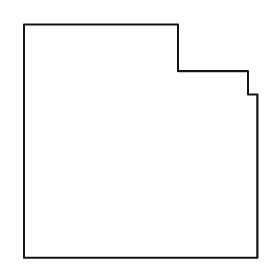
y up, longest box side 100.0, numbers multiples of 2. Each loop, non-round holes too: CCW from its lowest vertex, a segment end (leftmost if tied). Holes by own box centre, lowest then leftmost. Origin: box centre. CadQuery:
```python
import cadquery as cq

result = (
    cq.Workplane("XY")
    .moveTo(-50.0, -50.0)
    .lineTo(50.0, -50.0)
    .lineTo(50.0, 20.0)
    .lineTo(46.0, 20.0)
    .lineTo(46.0, 30.0)
    .lineTo(16.0, 30.0)
    .lineTo(16.0, 50.0)
    .lineTo(-50.0, 50.0)
    .close()
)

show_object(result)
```